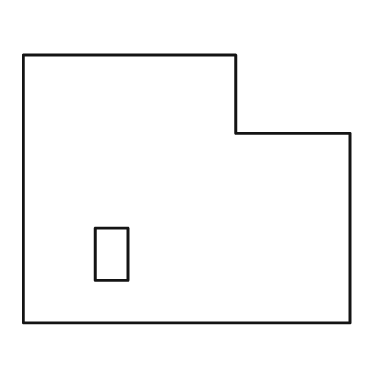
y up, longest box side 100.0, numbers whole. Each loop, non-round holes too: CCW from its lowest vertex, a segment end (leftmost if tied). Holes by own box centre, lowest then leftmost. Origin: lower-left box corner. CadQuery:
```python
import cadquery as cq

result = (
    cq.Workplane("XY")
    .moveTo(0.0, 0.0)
    .lineTo(100.0, 0.0)
    .lineTo(100.0, 58.0)
    .lineTo(65.0, 58.0)
    .lineTo(65.0, 82.0)
    .lineTo(0.0, 82.0)
    .close()
    .moveTo(22.0, 13.0)
    .lineTo(32.0, 13.0)
    .lineTo(32.0, 29.0)
    .lineTo(22.0, 29.0)
    .close()
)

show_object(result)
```